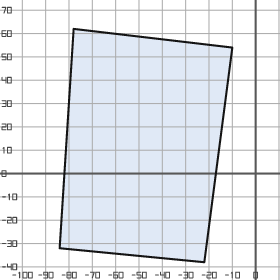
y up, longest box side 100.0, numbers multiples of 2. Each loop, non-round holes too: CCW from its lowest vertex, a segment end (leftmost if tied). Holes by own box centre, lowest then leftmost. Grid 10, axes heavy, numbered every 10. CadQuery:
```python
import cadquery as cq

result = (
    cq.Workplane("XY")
    .moveTo(-22.0, -38.0)
    .lineTo(-10.0, 54.0)
    .lineTo(-78.0, 62.0)
    .lineTo(-84.0, -32.0)
    .close()
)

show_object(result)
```